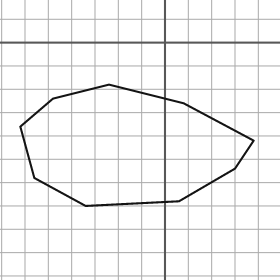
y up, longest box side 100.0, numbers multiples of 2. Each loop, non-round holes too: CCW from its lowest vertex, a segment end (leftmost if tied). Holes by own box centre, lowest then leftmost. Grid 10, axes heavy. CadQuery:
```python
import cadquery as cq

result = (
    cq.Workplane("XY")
    .moveTo(-34.0, -70.0)
    .lineTo(6.0, -68.0)
    .lineTo(30.0, -54.0)
    .lineTo(38.0, -42.0)
    .lineTo(8.0, -26.0)
    .lineTo(-24.0, -18.0)
    .lineTo(-48.0, -24.0)
    .lineTo(-62.0, -36.0)
    .lineTo(-56.0, -58.0)
    .close()
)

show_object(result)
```